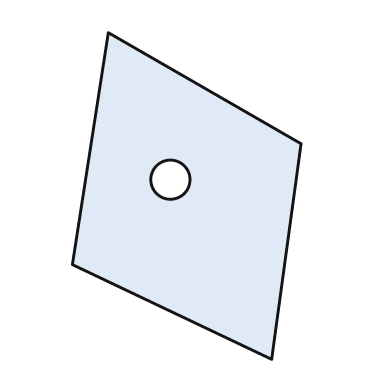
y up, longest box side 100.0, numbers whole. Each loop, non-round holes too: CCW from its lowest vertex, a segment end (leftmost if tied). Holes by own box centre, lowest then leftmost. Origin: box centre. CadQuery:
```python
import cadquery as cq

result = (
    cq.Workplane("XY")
    .moveTo(26.0, -50.0)
    .lineTo(35.0, 16.0)
    .lineTo(-24.0, 50.0)
    .lineTo(-35.0, -21.0)
    .close()
    .moveTo(-5.0, 5.0)
    .circle(6.0)
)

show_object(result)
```